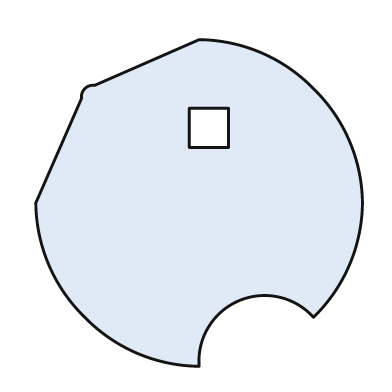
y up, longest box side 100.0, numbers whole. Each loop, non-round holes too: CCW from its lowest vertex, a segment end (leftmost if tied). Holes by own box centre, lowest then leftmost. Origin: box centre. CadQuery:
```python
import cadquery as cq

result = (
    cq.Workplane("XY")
    .moveTo(0.0, -50.0)
    .threePointArc((12.0, -30.0), (35.0, -35.0))
    .threePointArc((46.0, -19.0), (50.0, 0.0))
    .threePointArc((46.0, 19.0), (35.0, 35.0))
    .threePointArc((19.0, 46.0), (0.0, 50.0))
    .lineTo(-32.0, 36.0)
    .threePointArc((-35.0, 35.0), (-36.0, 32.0))
    .lineTo(-50.0, 0.0)
    .threePointArc((-46.0, -19.0), (-35.0, -35.0))
    .threePointArc((-19.0, -46.0), (0.0, -50.0))
    .close()
    .moveTo(-3.0, 17.0)
    .lineTo(9.0, 17.0)
    .lineTo(9.0, 29.0)
    .lineTo(-3.0, 29.0)
    .close()
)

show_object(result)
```